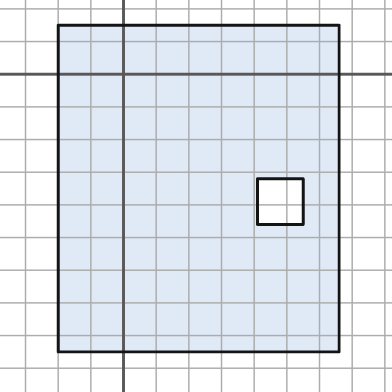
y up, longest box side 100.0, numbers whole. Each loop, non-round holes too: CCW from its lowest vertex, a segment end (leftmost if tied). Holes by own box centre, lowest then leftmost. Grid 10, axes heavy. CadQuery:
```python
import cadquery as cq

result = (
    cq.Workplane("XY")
    .moveTo(-20.0, -85.0)
    .lineTo(66.0, -85.0)
    .lineTo(66.0, 15.0)
    .lineTo(-20.0, 15.0)
    .close()
    .moveTo(41.0, -46.0)
    .lineTo(55.0, -46.0)
    .lineTo(55.0, -32.0)
    .lineTo(41.0, -32.0)
    .close()
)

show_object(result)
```